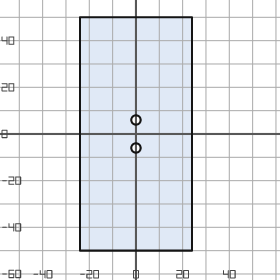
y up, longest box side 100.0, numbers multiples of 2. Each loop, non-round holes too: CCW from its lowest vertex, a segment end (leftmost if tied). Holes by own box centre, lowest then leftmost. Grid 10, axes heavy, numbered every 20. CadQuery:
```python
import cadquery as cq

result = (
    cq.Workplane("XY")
    .moveTo(-24.0, -50.0)
    .lineTo(24.0, -50.0)
    .lineTo(24.0, 50.0)
    .lineTo(-24.0, 50.0)
    .close()
    .moveTo(0.0, -6.0)
    .circle(2.0)
    .moveTo(0.0, 6.0)
    .circle(2.0)
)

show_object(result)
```